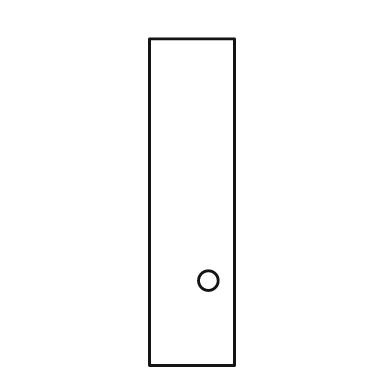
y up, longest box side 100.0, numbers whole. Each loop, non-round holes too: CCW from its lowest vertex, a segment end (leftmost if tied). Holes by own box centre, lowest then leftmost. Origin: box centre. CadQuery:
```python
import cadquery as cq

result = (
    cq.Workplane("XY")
    .moveTo(-13.0, -50.0)
    .lineTo(13.0, -50.0)
    .lineTo(13.0, 50.0)
    .lineTo(-13.0, 50.0)
    .close()
    .moveTo(5.0, -24.0)
    .circle(3.0)
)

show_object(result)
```